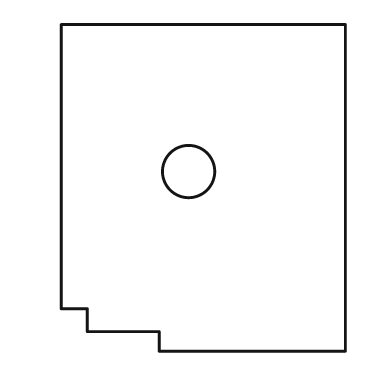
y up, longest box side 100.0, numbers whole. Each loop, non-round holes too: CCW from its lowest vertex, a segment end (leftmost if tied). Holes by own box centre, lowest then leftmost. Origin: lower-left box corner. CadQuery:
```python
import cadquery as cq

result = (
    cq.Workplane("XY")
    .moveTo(30.0, 0.0)
    .lineTo(87.0, 0.0)
    .lineTo(87.0, 100.0)
    .lineTo(0.0, 100.0)
    .lineTo(0.0, 13.0)
    .lineTo(8.0, 13.0)
    .lineTo(8.0, 6.0)
    .lineTo(30.0, 6.0)
    .close()
    .moveTo(39.0, 55.0)
    .circle(8.0)
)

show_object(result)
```